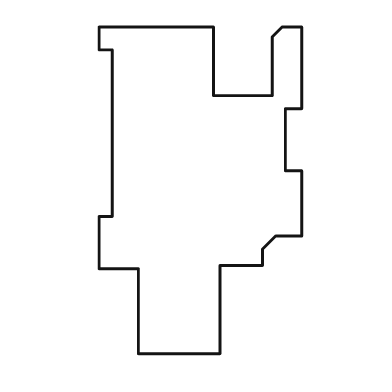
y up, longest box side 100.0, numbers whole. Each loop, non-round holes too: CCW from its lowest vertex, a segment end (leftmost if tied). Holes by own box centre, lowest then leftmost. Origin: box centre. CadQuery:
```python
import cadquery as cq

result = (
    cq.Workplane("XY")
    .moveTo(-19.0, -50.0)
    .lineTo(6.0, -50.0)
    .lineTo(6.0, -23.0)
    .lineTo(19.0, -23.0)
    .lineTo(19.0, -18.0)
    .lineTo(23.0, -14.0)
    .lineTo(31.0, -14.0)
    .lineTo(31.0, 6.0)
    .lineTo(26.0, 6.0)
    .lineTo(26.0, 25.0)
    .lineTo(31.0, 25.0)
    .lineTo(31.0, 50.0)
    .lineTo(25.0, 50.0)
    .lineTo(22.0, 47.0)
    .lineTo(22.0, 29.0)
    .lineTo(4.0, 29.0)
    .lineTo(4.0, 50.0)
    .lineTo(-31.0, 50.0)
    .lineTo(-31.0, 43.0)
    .lineTo(-27.0, 43.0)
    .lineTo(-27.0, -8.0)
    .lineTo(-31.0, -8.0)
    .lineTo(-31.0, -24.0)
    .lineTo(-19.0, -24.0)
    .close()
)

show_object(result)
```